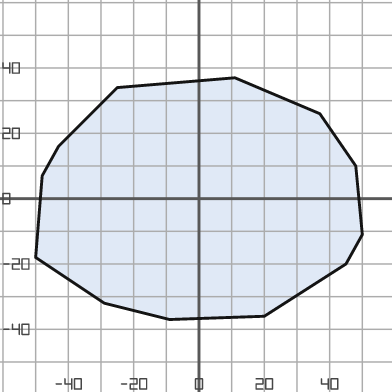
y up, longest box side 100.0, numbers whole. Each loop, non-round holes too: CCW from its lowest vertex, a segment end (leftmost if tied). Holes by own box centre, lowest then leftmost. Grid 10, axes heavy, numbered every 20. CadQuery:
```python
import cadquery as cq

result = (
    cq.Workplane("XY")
    .moveTo(-9.0, -37.0)
    .lineTo(20.0, -36.0)
    .lineTo(45.0, -20.0)
    .lineTo(50.0, -11.0)
    .lineTo(48.0, 10.0)
    .lineTo(37.0, 26.0)
    .lineTo(11.0, 37.0)
    .lineTo(-25.0, 34.0)
    .lineTo(-43.0, 16.0)
    .lineTo(-48.0, 7.0)
    .lineTo(-50.0, -18.0)
    .lineTo(-29.0, -32.0)
    .close()
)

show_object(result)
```